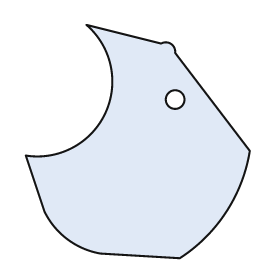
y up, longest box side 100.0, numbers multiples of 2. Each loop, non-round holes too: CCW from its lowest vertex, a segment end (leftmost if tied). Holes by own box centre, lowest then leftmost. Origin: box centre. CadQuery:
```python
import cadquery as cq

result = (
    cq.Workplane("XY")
    .moveTo(18.0, -50.0)
    .threePointArc((38.0, -30.0), (48.0, -4.0))
    .lineTo(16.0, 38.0)
    .threePointArc((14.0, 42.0), (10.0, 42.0))
    .lineTo(-22.0, 50.0)
    .threePointArc((-14.0, 12.0), (-48.0, -6.0))
    .lineTo(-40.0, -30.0)
    .threePointArc((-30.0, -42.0), (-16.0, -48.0))
    .close()
    .moveTo(16.0, 18.0)
    .circle(4.0)
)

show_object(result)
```